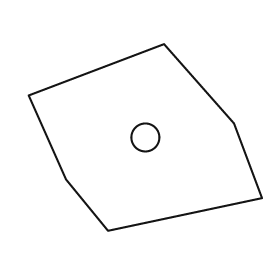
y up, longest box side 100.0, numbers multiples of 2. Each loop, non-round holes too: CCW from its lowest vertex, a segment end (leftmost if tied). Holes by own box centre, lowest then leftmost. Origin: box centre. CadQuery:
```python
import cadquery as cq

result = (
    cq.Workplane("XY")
    .moveTo(-16.0, -40.0)
    .lineTo(50.0, -26.0)
    .lineTo(38.0, 6.0)
    .lineTo(8.0, 40.0)
    .lineTo(-50.0, 18.0)
    .lineTo(-34.0, -18.0)
    .close()
    .moveTo(0.0, 0.0)
    .circle(6.0)
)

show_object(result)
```